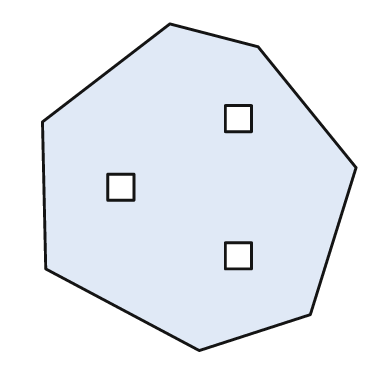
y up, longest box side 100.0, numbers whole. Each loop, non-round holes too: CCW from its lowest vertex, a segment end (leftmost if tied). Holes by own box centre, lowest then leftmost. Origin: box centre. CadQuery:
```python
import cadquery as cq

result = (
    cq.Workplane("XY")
    .moveTo(0.0, -50.0)
    .lineTo(34.0, -39.0)
    .lineTo(48.0, 6.0)
    .lineTo(18.0, 43.0)
    .lineTo(-9.0, 50.0)
    .lineTo(-48.0, 20.0)
    .lineTo(-47.0, -25.0)
    .close()
    .moveTo(8.0, -25.0)
    .lineTo(16.0, -25.0)
    .lineTo(16.0, -17.0)
    .lineTo(8.0, -17.0)
    .close()
    .moveTo(-28.0, -4.0)
    .lineTo(-20.0, -4.0)
    .lineTo(-20.0, 4.0)
    .lineTo(-28.0, 4.0)
    .close()
    .moveTo(8.0, 17.0)
    .lineTo(16.0, 17.0)
    .lineTo(16.0, 25.0)
    .lineTo(8.0, 25.0)
    .close()
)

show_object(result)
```